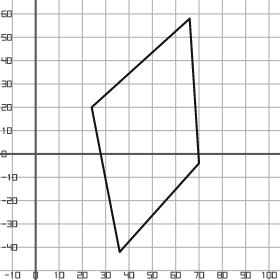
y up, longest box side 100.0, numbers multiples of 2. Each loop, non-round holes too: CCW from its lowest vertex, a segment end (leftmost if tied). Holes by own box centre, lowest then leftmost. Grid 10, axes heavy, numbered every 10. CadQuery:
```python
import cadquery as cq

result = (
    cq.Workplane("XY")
    .moveTo(36.0, -42.0)
    .lineTo(70.0, -4.0)
    .lineTo(66.0, 58.0)
    .lineTo(24.0, 20.0)
    .close()
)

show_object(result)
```